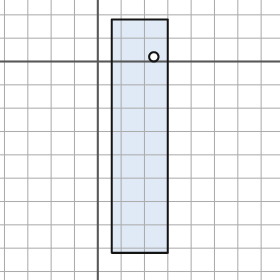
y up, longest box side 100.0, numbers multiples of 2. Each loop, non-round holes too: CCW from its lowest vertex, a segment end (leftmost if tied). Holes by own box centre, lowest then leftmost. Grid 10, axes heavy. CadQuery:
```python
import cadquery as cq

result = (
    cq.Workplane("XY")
    .moveTo(6.0, -82.0)
    .lineTo(30.0, -82.0)
    .lineTo(30.0, 18.0)
    .lineTo(6.0, 18.0)
    .close()
    .moveTo(24.0, 2.0)
    .circle(2.0)
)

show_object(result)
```